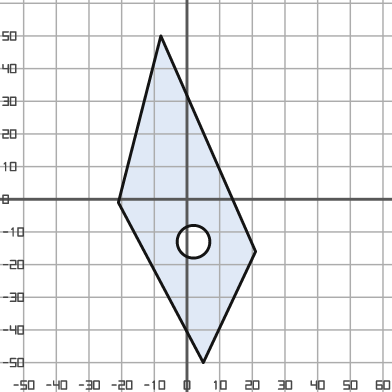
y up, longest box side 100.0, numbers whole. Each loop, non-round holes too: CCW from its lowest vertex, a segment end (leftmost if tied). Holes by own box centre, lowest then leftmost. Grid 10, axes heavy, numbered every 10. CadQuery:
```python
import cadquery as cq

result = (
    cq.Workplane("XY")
    .moveTo(5.0, -50.0)
    .lineTo(21.0, -16.0)
    .lineTo(-8.0, 50.0)
    .lineTo(-21.0, -1.0)
    .close()
    .moveTo(2.0, -13.0)
    .circle(5.0)
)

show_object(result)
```